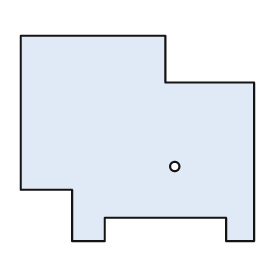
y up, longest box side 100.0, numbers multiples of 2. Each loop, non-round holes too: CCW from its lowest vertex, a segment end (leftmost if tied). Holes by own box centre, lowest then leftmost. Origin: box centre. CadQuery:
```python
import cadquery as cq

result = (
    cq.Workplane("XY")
    .moveTo(-28.0, -44.0)
    .lineTo(-14.0, -44.0)
    .lineTo(-14.0, -34.0)
    .lineTo(38.0, -34.0)
    .lineTo(38.0, -44.0)
    .lineTo(50.0, -44.0)
    .lineTo(50.0, 24.0)
    .lineTo(12.0, 24.0)
    .lineTo(12.0, 44.0)
    .lineTo(-50.0, 44.0)
    .lineTo(-50.0, -22.0)
    .lineTo(-28.0, -22.0)
    .close()
    .moveTo(16.0, -12.0)
    .circle(2.0)
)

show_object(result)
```